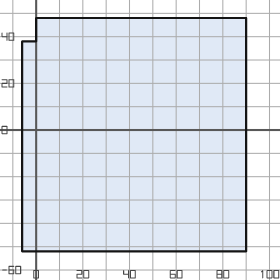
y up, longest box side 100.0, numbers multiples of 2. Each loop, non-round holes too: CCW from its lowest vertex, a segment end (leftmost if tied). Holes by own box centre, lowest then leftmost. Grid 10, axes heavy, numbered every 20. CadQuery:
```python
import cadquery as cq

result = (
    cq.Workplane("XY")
    .moveTo(-6.0, -52.0)
    .lineTo(90.0, -52.0)
    .lineTo(90.0, 48.0)
    .lineTo(0.0, 48.0)
    .lineTo(0.0, 38.0)
    .lineTo(-6.0, 38.0)
    .close()
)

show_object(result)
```